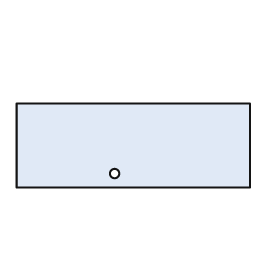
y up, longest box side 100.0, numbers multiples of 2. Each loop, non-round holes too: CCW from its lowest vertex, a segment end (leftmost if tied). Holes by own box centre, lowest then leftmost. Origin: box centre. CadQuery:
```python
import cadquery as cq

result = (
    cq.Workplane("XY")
    .moveTo(-50.0, -18.0)
    .lineTo(50.0, -18.0)
    .lineTo(50.0, 18.0)
    .lineTo(-50.0, 18.0)
    .close()
    .moveTo(-8.0, -12.0)
    .circle(2.0)
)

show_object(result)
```